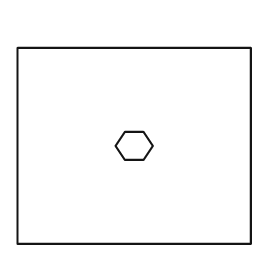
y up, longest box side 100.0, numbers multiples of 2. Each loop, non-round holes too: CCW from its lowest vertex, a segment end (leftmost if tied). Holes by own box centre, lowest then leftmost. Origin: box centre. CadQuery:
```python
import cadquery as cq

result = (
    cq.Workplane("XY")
    .moveTo(-50.0, -42.0)
    .lineTo(50.0, -42.0)
    .lineTo(50.0, 42.0)
    .lineTo(-50.0, 42.0)
    .close()
    .moveTo(-4.0, -6.0)
    .lineTo(4.0, -6.0)
    .lineTo(8.0, 0.0)
    .lineTo(4.0, 6.0)
    .lineTo(-4.0, 6.0)
    .lineTo(-8.0, 0.0)
    .close()
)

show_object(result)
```